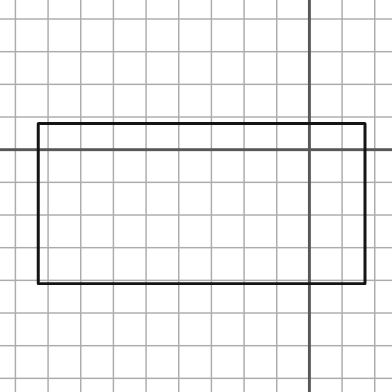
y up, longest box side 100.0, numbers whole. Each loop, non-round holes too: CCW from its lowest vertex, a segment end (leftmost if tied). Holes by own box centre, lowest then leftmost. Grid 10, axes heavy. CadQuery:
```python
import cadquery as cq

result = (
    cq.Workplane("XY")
    .moveTo(-83.0, -41.0)
    .lineTo(17.0, -41.0)
    .lineTo(17.0, 8.0)
    .lineTo(-83.0, 8.0)
    .close()
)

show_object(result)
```